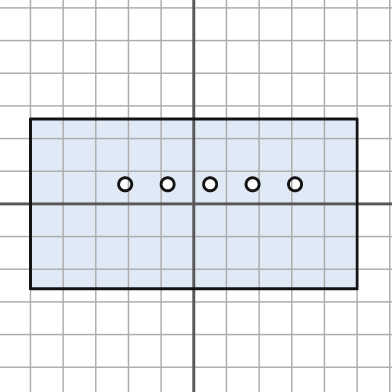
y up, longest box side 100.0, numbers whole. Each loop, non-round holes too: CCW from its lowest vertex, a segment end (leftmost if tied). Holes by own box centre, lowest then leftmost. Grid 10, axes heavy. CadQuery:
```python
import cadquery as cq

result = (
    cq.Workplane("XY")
    .moveTo(-50.0, -26.0)
    .lineTo(50.0, -26.0)
    .lineTo(50.0, 26.0)
    .lineTo(-50.0, 26.0)
    .close()
    .moveTo(-21.0, 6.0)
    .circle(2.0)
    .moveTo(-8.0, 6.0)
    .circle(2.0)
    .moveTo(5.0, 6.0)
    .circle(2.0)
    .moveTo(18.0, 6.0)
    .circle(2.0)
    .moveTo(31.0, 6.0)
    .circle(2.0)
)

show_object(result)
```